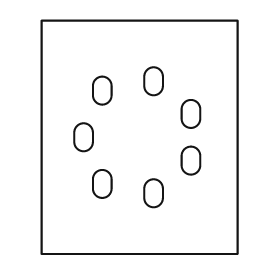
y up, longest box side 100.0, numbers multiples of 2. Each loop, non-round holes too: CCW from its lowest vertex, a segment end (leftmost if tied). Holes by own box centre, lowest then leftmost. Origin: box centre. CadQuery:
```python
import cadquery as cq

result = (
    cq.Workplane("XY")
    .moveTo(-42.0, -50.0)
    .lineTo(42.0, -50.0)
    .lineTo(42.0, 50.0)
    .lineTo(-42.0, 50.0)
    .close()
    .moveTo(2.0, -26.0)
    .threePointArc((6.0, -30.0), (10.0, -26.0))
    .lineTo(10.0, -22.0)
    .threePointArc((6.0, -18.0), (2.0, -22.0))
    .close()
    .moveTo(-20.0, -22.0)
    .threePointArc((-16.0, -26.0), (-12.0, -22.0))
    .lineTo(-12.0, -18.0)
    .threePointArc((-16.0, -14.0), (-20.0, -18.0))
    .close()
    .moveTo(18.0, -12.0)
    .threePointArc((22.0, -16.0), (26.0, -12.0))
    .lineTo(26.0, -8.0)
    .threePointArc((22.0, -4.0), (18.0, -8.0))
    .close()
    .moveTo(-28.0, -2.0)
    .threePointArc((-24.0, -6.0), (-20.0, -2.0))
    .lineTo(-20.0, 2.0)
    .threePointArc((-24.0, 6.0), (-28.0, 2.0))
    .close()
    .moveTo(18.0, 8.0)
    .threePointArc((22.0, 4.0), (26.0, 8.0))
    .lineTo(26.0, 12.0)
    .threePointArc((22.0, 16.0), (18.0, 12.0))
    .close()
    .moveTo(-20.0, 18.0)
    .threePointArc((-16.0, 14.0), (-12.0, 18.0))
    .lineTo(-12.0, 22.0)
    .threePointArc((-16.0, 26.0), (-20.0, 22.0))
    .close()
    .moveTo(2.0, 22.0)
    .threePointArc((6.0, 18.0), (10.0, 22.0))
    .lineTo(10.0, 26.0)
    .threePointArc((6.0, 30.0), (2.0, 26.0))
    .close()
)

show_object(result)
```